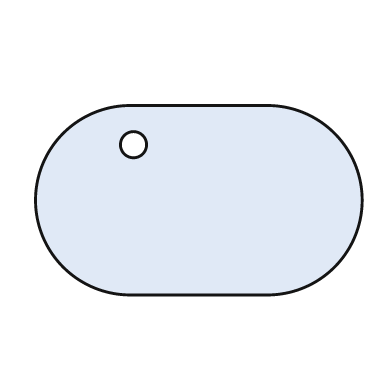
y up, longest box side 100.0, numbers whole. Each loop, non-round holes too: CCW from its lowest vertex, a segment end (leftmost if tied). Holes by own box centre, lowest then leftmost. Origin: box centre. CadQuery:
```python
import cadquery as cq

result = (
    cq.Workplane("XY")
    .moveTo(-21.0, -29.0)
    .lineTo(21.0, -29.0)
    .threePointArc((50.0, 0.0), (21.0, 29.0))
    .lineTo(-21.0, 29.0)
    .threePointArc((-50.0, 0.0), (-21.0, -29.0))
    .close()
    .moveTo(-20.0, 17.0)
    .circle(4.0)
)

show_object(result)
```